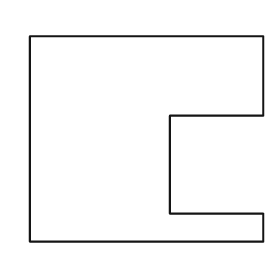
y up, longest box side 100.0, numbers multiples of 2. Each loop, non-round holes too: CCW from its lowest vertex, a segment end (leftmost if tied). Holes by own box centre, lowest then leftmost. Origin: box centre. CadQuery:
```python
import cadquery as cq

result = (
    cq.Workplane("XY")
    .moveTo(-50.0, -44.0)
    .lineTo(50.0, -44.0)
    .lineTo(50.0, -32.0)
    .lineTo(10.0, -32.0)
    .lineTo(10.0, 10.0)
    .lineTo(50.0, 10.0)
    .lineTo(50.0, 44.0)
    .lineTo(-50.0, 44.0)
    .close()
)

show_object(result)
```